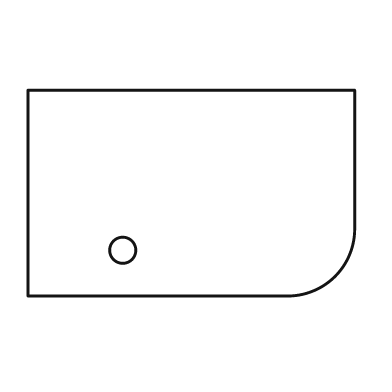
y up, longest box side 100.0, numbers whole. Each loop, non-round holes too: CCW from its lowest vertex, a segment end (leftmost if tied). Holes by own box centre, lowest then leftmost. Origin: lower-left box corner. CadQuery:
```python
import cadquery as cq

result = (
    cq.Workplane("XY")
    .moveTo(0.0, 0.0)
    .lineTo(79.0, 0.0)
    .threePointArc((94.0, 6.0), (100.0, 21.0))
    .lineTo(100.0, 63.0)
    .lineTo(0.0, 63.0)
    .close()
    .moveTo(29.0, 14.0)
    .circle(4.0)
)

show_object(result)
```